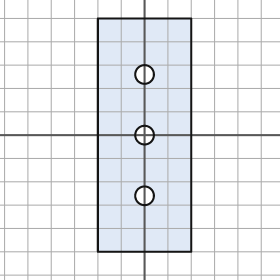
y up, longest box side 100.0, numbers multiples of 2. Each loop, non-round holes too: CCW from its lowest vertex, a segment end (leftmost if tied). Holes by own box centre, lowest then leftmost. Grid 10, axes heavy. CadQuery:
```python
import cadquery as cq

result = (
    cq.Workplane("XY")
    .moveTo(-20.0, -50.0)
    .lineTo(20.0, -50.0)
    .lineTo(20.0, 50.0)
    .lineTo(-20.0, 50.0)
    .close()
    .moveTo(0.0, -26.0)
    .circle(4.0)
    .moveTo(0.0, 0.0)
    .circle(4.0)
    .moveTo(0.0, 26.0)
    .circle(4.0)
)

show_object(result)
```